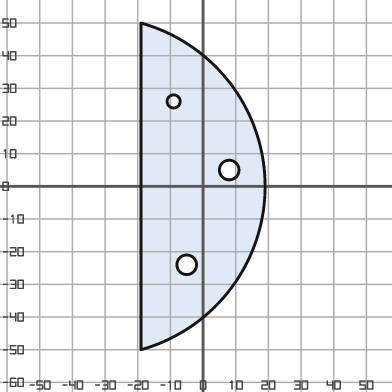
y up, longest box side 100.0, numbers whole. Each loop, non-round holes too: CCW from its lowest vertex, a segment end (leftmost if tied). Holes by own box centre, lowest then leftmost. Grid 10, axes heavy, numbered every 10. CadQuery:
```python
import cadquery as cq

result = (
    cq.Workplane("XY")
    .moveTo(-19.0, -50.0)
    .threePointArc((19.0, 0.0), (-19.0, 50.0))
    .close()
    .moveTo(-5.0, -24.0)
    .circle(3.0)
    .moveTo(8.0, 5.0)
    .circle(3.0)
    .moveTo(-9.0, 26.0)
    .circle(2.0)
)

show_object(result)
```